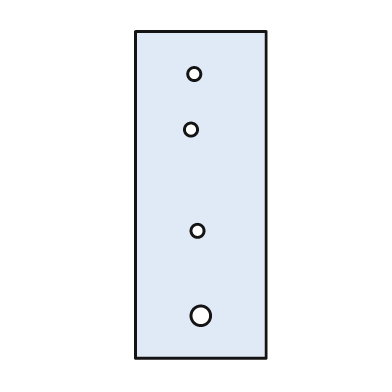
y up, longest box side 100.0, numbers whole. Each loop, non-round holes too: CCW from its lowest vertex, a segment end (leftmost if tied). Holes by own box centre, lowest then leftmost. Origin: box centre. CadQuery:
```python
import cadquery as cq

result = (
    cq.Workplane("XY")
    .moveTo(-20.0, -50.0)
    .lineTo(20.0, -50.0)
    .lineTo(20.0, 50.0)
    .lineTo(-20.0, 50.0)
    .close()
    .moveTo(0.0, -37.0)
    .circle(3.0)
    .moveTo(-1.0, -11.0)
    .circle(2.0)
    .moveTo(-3.0, 20.0)
    .circle(2.0)
    .moveTo(-2.0, 37.0)
    .circle(2.0)
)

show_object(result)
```